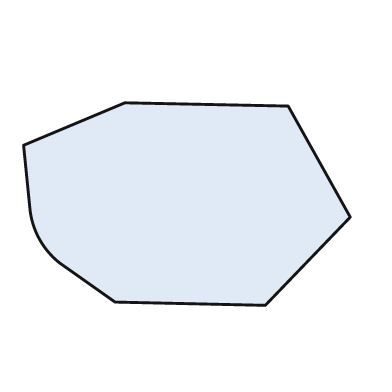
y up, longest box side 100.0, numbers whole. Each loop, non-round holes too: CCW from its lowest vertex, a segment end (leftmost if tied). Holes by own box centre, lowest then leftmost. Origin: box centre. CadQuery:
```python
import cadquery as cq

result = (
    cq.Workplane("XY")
    .moveTo(24.0, -31.0)
    .lineTo(50.0, -4.0)
    .lineTo(31.0, 30.0)
    .lineTo(-19.0, 31.0)
    .lineTo(-50.0, 18.0)
    .lineTo(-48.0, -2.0)
    .threePointArc((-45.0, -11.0), (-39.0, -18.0))
    .lineTo(-22.0, -30.0)
    .close()
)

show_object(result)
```